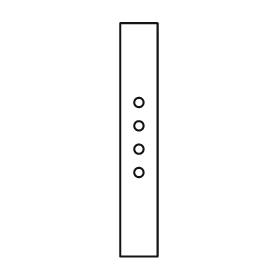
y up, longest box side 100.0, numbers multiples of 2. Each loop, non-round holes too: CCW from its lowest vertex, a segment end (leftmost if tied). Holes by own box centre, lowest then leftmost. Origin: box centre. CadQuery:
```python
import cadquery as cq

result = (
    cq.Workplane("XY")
    .moveTo(-8.0, -50.0)
    .lineTo(8.0, -50.0)
    .lineTo(8.0, 50.0)
    .lineTo(-8.0, 50.0)
    .close()
    .moveTo(0.0, -14.0)
    .circle(2.0)
    .moveTo(0.0, -4.0)
    .circle(2.0)
    .moveTo(0.0, 6.0)
    .circle(2.0)
    .moveTo(0.0, 16.0)
    .circle(2.0)
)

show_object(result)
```